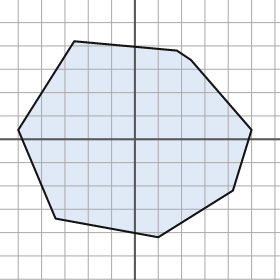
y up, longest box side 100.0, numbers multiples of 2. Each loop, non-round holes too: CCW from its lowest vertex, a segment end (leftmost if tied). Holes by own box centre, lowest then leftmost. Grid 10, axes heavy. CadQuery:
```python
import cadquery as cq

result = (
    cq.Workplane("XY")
    .moveTo(10.0, -42.0)
    .lineTo(42.0, -22.0)
    .lineTo(50.0, 4.0)
    .lineTo(24.0, 34.0)
    .lineTo(18.0, 38.0)
    .lineTo(-26.0, 42.0)
    .lineTo(-50.0, 4.0)
    .lineTo(-34.0, -34.0)
    .close()
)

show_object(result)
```